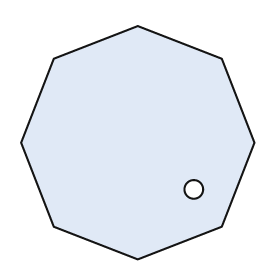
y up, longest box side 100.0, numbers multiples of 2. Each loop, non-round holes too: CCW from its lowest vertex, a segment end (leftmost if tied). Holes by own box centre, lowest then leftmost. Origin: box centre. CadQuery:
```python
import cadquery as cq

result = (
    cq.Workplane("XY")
    .moveTo(0.0, -50.0)
    .lineTo(36.0, -36.0)
    .lineTo(50.0, 0.0)
    .lineTo(36.0, 36.0)
    .lineTo(0.0, 50.0)
    .lineTo(-36.0, 36.0)
    .lineTo(-50.0, 0.0)
    .lineTo(-36.0, -36.0)
    .close()
    .moveTo(24.0, -20.0)
    .circle(4.0)
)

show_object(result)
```